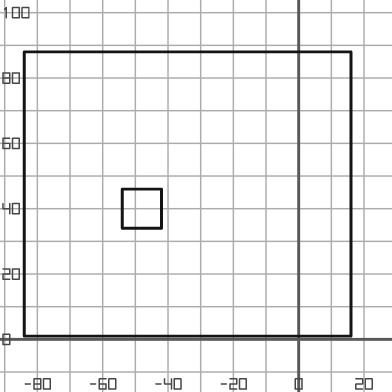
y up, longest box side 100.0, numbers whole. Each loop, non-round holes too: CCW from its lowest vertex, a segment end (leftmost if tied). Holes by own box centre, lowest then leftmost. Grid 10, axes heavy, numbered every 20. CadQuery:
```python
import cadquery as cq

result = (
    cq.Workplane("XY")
    .moveTo(-84.0, 1.0)
    .lineTo(16.0, 1.0)
    .lineTo(16.0, 88.0)
    .lineTo(-84.0, 88.0)
    .close()
    .moveTo(-54.0, 34.0)
    .lineTo(-42.0, 34.0)
    .lineTo(-42.0, 46.0)
    .lineTo(-54.0, 46.0)
    .close()
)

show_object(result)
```